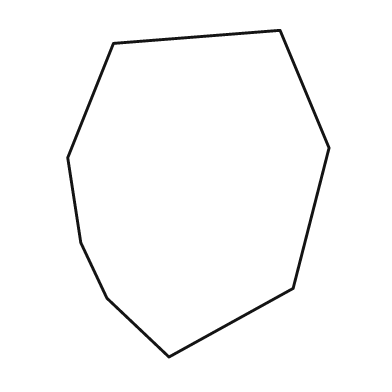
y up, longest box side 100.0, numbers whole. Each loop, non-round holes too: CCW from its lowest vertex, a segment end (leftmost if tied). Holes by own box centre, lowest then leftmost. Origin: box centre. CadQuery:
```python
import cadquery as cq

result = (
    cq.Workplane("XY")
    .moveTo(-9.0, -50.0)
    .lineTo(29.0, -29.0)
    .lineTo(40.0, 14.0)
    .lineTo(25.0, 50.0)
    .lineTo(-26.0, 46.0)
    .lineTo(-40.0, 11.0)
    .lineTo(-36.0, -15.0)
    .lineTo(-28.0, -32.0)
    .close()
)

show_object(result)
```